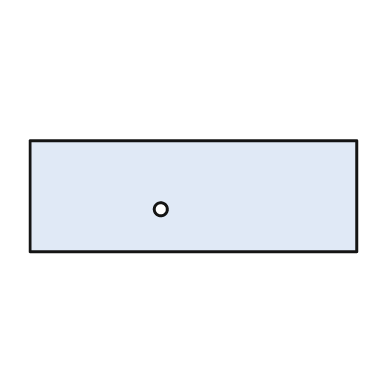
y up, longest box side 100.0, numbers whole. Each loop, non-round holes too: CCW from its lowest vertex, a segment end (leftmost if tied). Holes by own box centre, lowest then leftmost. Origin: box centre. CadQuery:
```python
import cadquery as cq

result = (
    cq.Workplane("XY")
    .moveTo(-50.0, -17.0)
    .lineTo(50.0, -17.0)
    .lineTo(50.0, 17.0)
    .lineTo(-50.0, 17.0)
    .close()
    .moveTo(-10.0, -4.0)
    .circle(2.0)
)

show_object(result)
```